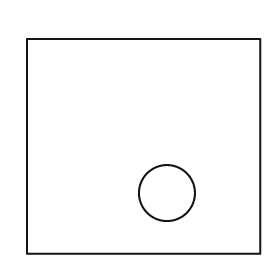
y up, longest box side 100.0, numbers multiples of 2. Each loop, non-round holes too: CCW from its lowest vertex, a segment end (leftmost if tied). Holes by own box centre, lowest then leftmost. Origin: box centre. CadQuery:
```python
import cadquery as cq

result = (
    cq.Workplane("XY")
    .moveTo(-50.0, -46.0)
    .lineTo(50.0, -46.0)
    .lineTo(50.0, 46.0)
    .lineTo(-50.0, 46.0)
    .close()
    .moveTo(10.0, -20.0)
    .circle(12.0)
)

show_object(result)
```